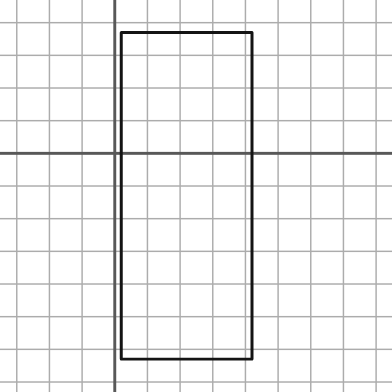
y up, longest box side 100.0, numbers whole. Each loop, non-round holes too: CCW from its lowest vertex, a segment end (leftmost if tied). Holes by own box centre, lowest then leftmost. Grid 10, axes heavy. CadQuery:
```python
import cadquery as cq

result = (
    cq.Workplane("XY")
    .moveTo(2.0, -63.0)
    .lineTo(42.0, -63.0)
    .lineTo(42.0, 37.0)
    .lineTo(2.0, 37.0)
    .close()
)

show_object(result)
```